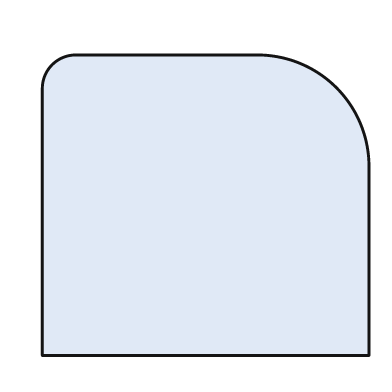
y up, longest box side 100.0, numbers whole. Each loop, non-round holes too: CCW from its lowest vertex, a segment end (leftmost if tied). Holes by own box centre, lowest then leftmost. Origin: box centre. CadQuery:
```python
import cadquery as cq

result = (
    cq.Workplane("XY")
    .moveTo(-50.0, -46.0)
    .lineTo(50.0, -46.0)
    .lineTo(50.0, 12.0)
    .threePointArc((40.0, 36.0), (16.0, 46.0))
    .lineTo(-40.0, 46.0)
    .threePointArc((-47.0, 43.0), (-50.0, 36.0))
    .close()
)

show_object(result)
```